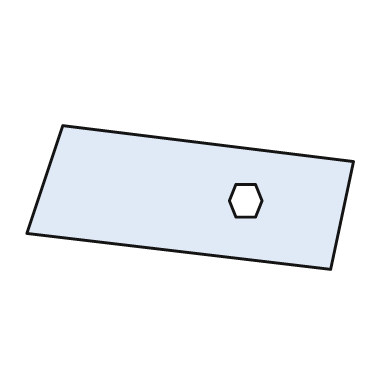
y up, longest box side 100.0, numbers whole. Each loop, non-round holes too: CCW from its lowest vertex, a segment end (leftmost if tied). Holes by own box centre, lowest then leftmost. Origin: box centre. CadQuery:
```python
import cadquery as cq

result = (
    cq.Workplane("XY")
    .moveTo(43.0, -22.0)
    .lineTo(50.0, 11.0)
    .lineTo(-39.0, 22.0)
    .lineTo(-50.0, -11.0)
    .close()
    .moveTo(14.0, -6.0)
    .lineTo(20.0, -6.0)
    .lineTo(22.0, -1.0)
    .lineTo(20.0, 4.0)
    .lineTo(14.0, 4.0)
    .lineTo(12.0, -1.0)
    .close()
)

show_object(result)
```